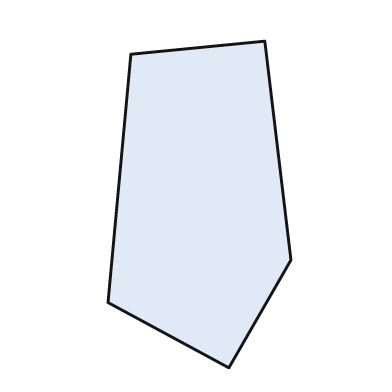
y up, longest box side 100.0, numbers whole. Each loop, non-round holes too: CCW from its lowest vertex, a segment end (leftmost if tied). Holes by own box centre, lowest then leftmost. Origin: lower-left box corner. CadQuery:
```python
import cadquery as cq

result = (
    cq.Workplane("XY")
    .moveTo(37.0, 0.0)
    .lineTo(56.0, 33.0)
    .lineTo(48.0, 100.0)
    .lineTo(7.0, 96.0)
    .lineTo(0.0, 20.0)
    .close()
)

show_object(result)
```